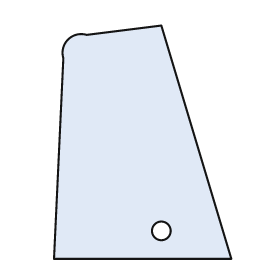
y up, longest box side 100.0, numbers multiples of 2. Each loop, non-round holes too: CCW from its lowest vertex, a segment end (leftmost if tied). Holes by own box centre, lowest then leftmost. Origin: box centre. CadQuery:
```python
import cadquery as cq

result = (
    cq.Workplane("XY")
    .moveTo(-38.0, -50.0)
    .lineTo(38.0, -50.0)
    .lineTo(8.0, 50.0)
    .lineTo(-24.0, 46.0)
    .threePointArc((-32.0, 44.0), (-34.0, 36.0))
    .close()
    .moveTo(8.0, -38.0)
    .circle(4.0)
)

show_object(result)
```